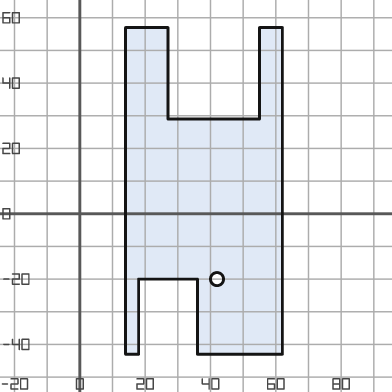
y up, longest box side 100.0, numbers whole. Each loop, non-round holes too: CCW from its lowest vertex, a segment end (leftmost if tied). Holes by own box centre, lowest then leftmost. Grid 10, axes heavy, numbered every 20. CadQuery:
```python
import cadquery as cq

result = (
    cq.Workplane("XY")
    .moveTo(14.0, -43.0)
    .lineTo(18.0, -43.0)
    .lineTo(18.0, -20.0)
    .lineTo(36.0, -20.0)
    .lineTo(36.0, -43.0)
    .lineTo(62.0, -43.0)
    .lineTo(62.0, 57.0)
    .lineTo(55.0, 57.0)
    .lineTo(55.0, 29.0)
    .lineTo(27.0, 29.0)
    .lineTo(27.0, 57.0)
    .lineTo(14.0, 57.0)
    .close()
    .moveTo(42.0, -20.0)
    .circle(2.0)
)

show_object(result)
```